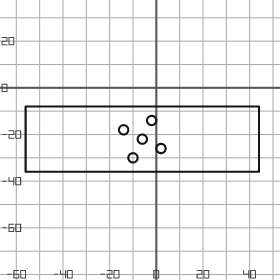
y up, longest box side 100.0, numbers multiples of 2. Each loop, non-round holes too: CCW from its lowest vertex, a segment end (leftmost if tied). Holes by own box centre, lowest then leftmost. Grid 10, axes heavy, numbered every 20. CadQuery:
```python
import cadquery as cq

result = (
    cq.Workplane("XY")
    .moveTo(-56.0, -36.0)
    .lineTo(44.0, -36.0)
    .lineTo(44.0, -8.0)
    .lineTo(-56.0, -8.0)
    .close()
    .moveTo(-10.0, -30.0)
    .circle(2.0)
    .moveTo(2.0, -26.0)
    .circle(2.0)
    .moveTo(-6.0, -22.0)
    .circle(2.0)
    .moveTo(-14.0, -18.0)
    .circle(2.0)
    .moveTo(-2.0, -14.0)
    .circle(2.0)
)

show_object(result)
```